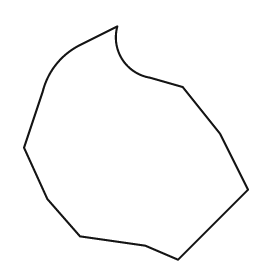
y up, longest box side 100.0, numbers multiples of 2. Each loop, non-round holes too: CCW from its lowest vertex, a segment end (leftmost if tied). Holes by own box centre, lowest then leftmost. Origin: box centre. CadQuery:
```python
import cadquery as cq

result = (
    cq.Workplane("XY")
    .moveTo(18.0, -50.0)
    .lineTo(48.0, -20.0)
    .lineTo(36.0, 4.0)
    .lineTo(20.0, 24.0)
    .lineTo(6.0, 28.0)
    .threePointArc((-6.0, 36.0), (-8.0, 50.0))
    .lineTo(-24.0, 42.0)
    .threePointArc((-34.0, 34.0), (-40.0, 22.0))
    .lineTo(-48.0, -2.0)
    .lineTo(-38.0, -24.0)
    .lineTo(-24.0, -40.0)
    .lineTo(4.0, -44.0)
    .close()
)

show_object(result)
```